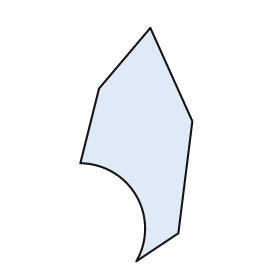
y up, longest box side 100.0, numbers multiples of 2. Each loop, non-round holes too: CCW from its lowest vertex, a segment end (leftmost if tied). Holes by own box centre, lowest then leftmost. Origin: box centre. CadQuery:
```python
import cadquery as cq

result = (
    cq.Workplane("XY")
    .moveTo(0.0, -50.0)
    .lineTo(18.0, -38.0)
    .lineTo(24.0, 10.0)
    .lineTo(6.0, 50.0)
    .lineTo(-16.0, 24.0)
    .lineTo(-24.0, -8.0)
    .threePointArc((0.0, -22.0), (0.0, -50.0))
    .close()
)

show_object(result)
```